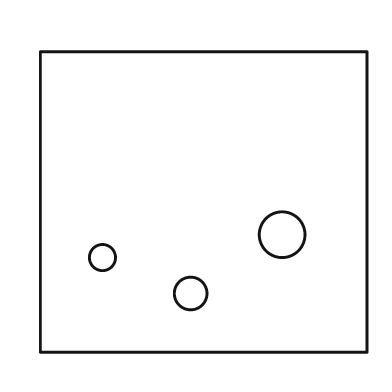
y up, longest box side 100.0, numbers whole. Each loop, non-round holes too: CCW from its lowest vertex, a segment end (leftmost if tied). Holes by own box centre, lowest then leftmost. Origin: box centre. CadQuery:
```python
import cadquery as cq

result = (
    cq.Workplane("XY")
    .moveTo(-50.0, -46.0)
    .lineTo(50.0, -46.0)
    .lineTo(50.0, 46.0)
    .lineTo(-50.0, 46.0)
    .close()
    .moveTo(-4.0, -28.0)
    .circle(5.0)
    .moveTo(-31.0, -17.0)
    .circle(4.0)
    .moveTo(24.0, -10.0)
    .circle(7.0)
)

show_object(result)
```